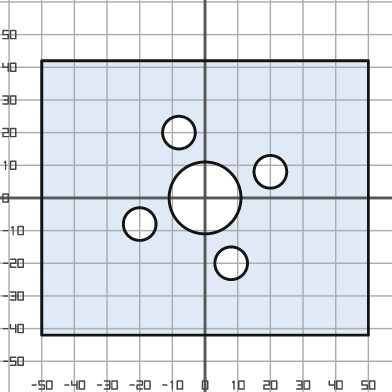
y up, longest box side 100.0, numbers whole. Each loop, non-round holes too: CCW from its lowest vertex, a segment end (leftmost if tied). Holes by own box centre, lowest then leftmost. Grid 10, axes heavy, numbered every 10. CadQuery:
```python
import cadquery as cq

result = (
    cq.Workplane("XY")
    .moveTo(-50.0, -42.0)
    .lineTo(50.0, -42.0)
    .lineTo(50.0, 42.0)
    .lineTo(-50.0, 42.0)
    .close()
    .moveTo(8.0, -20.0)
    .circle(5.0)
    .moveTo(-20.0, -8.0)
    .circle(5.0)
    .moveTo(0.0, 0.0)
    .circle(11.0)
    .moveTo(20.0, 8.0)
    .circle(5.0)
    .moveTo(-8.0, 20.0)
    .circle(5.0)
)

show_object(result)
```